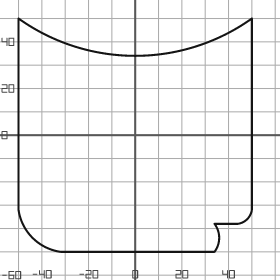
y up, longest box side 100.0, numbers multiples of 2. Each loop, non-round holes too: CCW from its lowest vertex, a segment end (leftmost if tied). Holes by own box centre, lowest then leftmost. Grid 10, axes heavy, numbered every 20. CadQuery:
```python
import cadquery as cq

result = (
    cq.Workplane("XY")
    .moveTo(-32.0, -50.0)
    .lineTo(34.0, -50.0)
    .threePointArc((36.0, -44.0), (34.0, -38.0))
    .lineTo(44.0, -38.0)
    .threePointArc((48.0, -36.0), (50.0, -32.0))
    .lineTo(50.0, 50.0)
    .threePointArc((0.0, 34.0), (-50.0, 50.0))
    .lineTo(-50.0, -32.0)
    .threePointArc((-44.0, -44.0), (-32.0, -50.0))
    .close()
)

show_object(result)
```